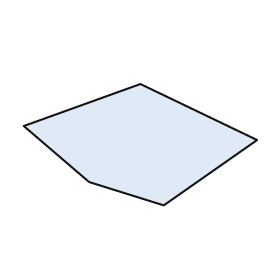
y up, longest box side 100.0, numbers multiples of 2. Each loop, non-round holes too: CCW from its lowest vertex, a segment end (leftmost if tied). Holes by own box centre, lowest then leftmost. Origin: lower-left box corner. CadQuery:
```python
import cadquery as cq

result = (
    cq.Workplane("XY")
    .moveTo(60.0, 0.0)
    .lineTo(100.0, 28.0)
    .lineTo(50.0, 52.0)
    .lineTo(0.0, 34.0)
    .lineTo(28.0, 10.0)
    .close()
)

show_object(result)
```